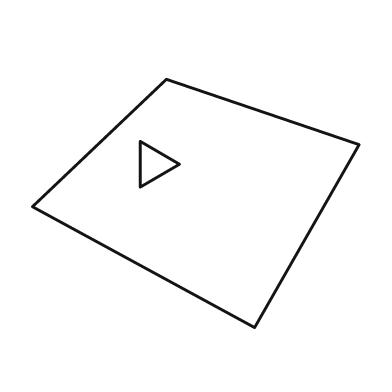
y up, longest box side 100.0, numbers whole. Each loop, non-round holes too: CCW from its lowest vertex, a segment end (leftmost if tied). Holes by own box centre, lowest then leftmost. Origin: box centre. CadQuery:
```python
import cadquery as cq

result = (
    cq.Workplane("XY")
    .moveTo(18.0, -38.0)
    .lineTo(50.0, 18.0)
    .lineTo(-9.0, 38.0)
    .lineTo(-50.0, -1.0)
    .close()
    .moveTo(-17.0, 5.0)
    .lineTo(-5.0, 12.0)
    .lineTo(-17.0, 19.0)
    .close()
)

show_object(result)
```